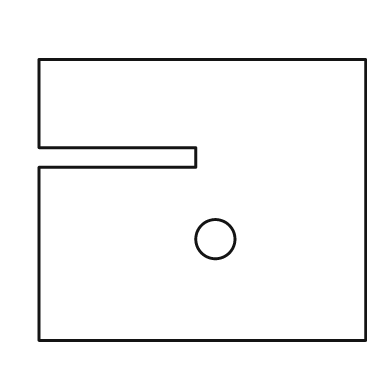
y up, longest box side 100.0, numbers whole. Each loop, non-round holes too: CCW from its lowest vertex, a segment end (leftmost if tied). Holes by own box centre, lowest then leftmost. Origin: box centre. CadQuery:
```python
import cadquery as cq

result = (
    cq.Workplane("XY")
    .moveTo(-50.0, -43.0)
    .lineTo(50.0, -43.0)
    .lineTo(50.0, 43.0)
    .lineTo(-50.0, 43.0)
    .lineTo(-50.0, 16.0)
    .lineTo(-2.0, 16.0)
    .lineTo(-2.0, 10.0)
    .lineTo(-50.0, 10.0)
    .close()
    .moveTo(4.0, -12.0)
    .circle(6.0)
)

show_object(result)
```